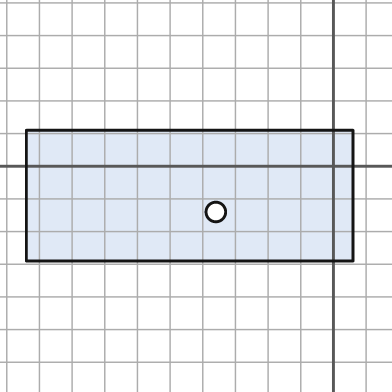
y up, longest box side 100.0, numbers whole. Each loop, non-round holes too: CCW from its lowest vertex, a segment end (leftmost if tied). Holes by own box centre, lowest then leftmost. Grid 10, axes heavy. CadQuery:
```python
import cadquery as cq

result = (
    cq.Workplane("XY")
    .moveTo(-94.0, -29.0)
    .lineTo(6.0, -29.0)
    .lineTo(6.0, 11.0)
    .lineTo(-94.0, 11.0)
    .close()
    .moveTo(-36.0, -14.0)
    .circle(3.0)
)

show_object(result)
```